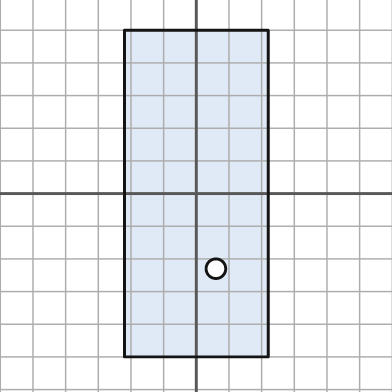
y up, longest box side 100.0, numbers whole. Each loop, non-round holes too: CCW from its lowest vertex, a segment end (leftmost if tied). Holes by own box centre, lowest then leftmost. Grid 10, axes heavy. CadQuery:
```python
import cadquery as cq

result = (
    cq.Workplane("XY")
    .moveTo(-22.0, -50.0)
    .lineTo(22.0, -50.0)
    .lineTo(22.0, 50.0)
    .lineTo(-22.0, 50.0)
    .close()
    .moveTo(6.0, -23.0)
    .circle(3.0)
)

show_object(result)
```